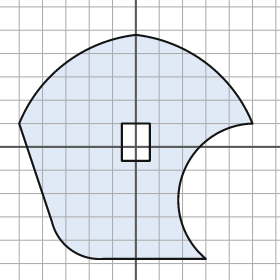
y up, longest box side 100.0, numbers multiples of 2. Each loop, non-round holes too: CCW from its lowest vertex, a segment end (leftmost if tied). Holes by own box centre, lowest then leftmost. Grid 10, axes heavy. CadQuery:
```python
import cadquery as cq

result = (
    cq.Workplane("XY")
    .moveTo(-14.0, -48.0)
    .lineTo(30.0, -48.0)
    .threePointArc((20.0, -12.0), (50.0, 10.0))
    .threePointArc((30.0, 36.0), (0.0, 48.0))
    .threePointArc((-30.0, 36.0), (-50.0, 10.0))
    .lineTo(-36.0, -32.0)
    .threePointArc((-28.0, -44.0), (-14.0, -48.0))
    .close()
    .moveTo(-6.0, -6.0)
    .lineTo(6.0, -6.0)
    .lineTo(6.0, 10.0)
    .lineTo(-6.0, 10.0)
    .close()
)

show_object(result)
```